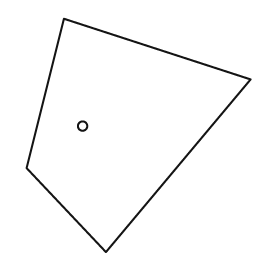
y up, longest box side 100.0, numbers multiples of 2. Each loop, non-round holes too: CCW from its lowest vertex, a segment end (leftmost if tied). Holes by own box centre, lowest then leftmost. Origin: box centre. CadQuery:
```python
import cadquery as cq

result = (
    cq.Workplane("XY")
    .moveTo(-14.0, -50.0)
    .lineTo(48.0, 24.0)
    .lineTo(-32.0, 50.0)
    .lineTo(-48.0, -14.0)
    .close()
    .moveTo(-24.0, 4.0)
    .circle(2.0)
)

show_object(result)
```